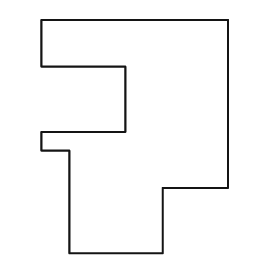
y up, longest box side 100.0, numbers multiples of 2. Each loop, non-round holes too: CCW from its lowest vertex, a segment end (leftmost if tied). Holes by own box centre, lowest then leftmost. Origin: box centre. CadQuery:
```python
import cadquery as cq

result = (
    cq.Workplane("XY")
    .moveTo(-28.0, -50.0)
    .lineTo(12.0, -50.0)
    .lineTo(12.0, -22.0)
    .lineTo(40.0, -22.0)
    .lineTo(40.0, 50.0)
    .lineTo(-40.0, 50.0)
    .lineTo(-40.0, 30.0)
    .lineTo(-4.0, 30.0)
    .lineTo(-4.0, 2.0)
    .lineTo(-40.0, 2.0)
    .lineTo(-40.0, -6.0)
    .lineTo(-28.0, -6.0)
    .close()
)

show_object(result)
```